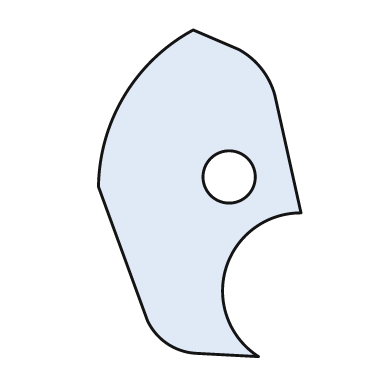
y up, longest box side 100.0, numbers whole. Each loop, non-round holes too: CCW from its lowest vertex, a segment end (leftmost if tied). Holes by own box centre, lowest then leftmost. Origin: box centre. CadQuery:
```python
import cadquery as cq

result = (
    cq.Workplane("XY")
    .moveTo(18.0, -50.0)
    .threePointArc((8.0, -23.0), (31.0, -6.0))
    .lineTo(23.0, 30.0)
    .threePointArc((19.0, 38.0), (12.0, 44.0))
    .lineTo(-2.0, 50.0)
    .threePointArc((-23.0, 30.0), (-31.0, 2.0))
    .lineTo(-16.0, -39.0)
    .threePointArc((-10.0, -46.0), (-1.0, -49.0))
    .close()
    .moveTo(9.0, 5.0)
    .circle(8.0)
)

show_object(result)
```